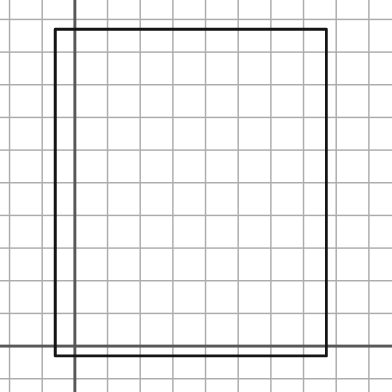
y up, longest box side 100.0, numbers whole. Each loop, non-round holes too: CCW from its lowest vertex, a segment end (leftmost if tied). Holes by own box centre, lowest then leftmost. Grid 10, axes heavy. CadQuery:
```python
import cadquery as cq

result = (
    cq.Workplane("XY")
    .moveTo(-6.0, -3.0)
    .lineTo(77.0, -3.0)
    .lineTo(77.0, 97.0)
    .lineTo(-6.0, 97.0)
    .close()
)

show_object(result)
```